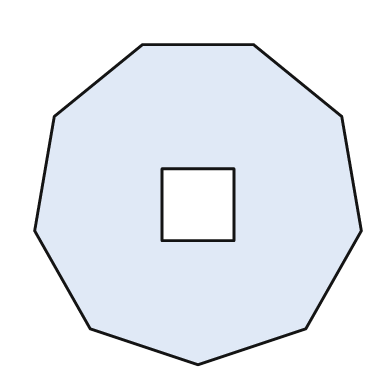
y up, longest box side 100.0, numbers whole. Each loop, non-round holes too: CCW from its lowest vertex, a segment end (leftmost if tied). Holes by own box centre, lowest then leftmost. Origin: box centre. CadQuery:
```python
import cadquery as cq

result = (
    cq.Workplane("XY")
    .moveTo(0.0, -49.0)
    .lineTo(33.0, -38.0)
    .lineTo(50.0, -8.0)
    .lineTo(44.0, 27.0)
    .lineTo(17.0, 49.0)
    .lineTo(-17.0, 49.0)
    .lineTo(-44.0, 27.0)
    .lineTo(-50.0, -8.0)
    .lineTo(-33.0, -38.0)
    .close()
    .moveTo(-11.0, -11.0)
    .lineTo(11.0, -11.0)
    .lineTo(11.0, 11.0)
    .lineTo(-11.0, 11.0)
    .close()
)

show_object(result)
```